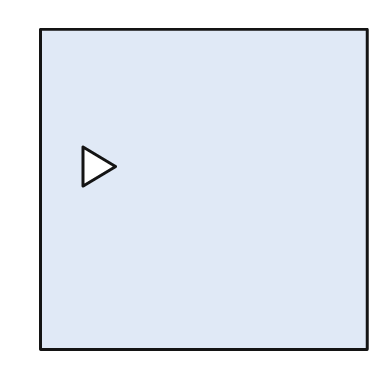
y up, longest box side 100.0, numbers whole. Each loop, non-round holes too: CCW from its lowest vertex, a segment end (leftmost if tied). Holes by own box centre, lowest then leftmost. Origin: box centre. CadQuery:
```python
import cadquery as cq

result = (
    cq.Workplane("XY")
    .moveTo(-50.0, -49.0)
    .lineTo(50.0, -49.0)
    .lineTo(50.0, 49.0)
    .lineTo(-50.0, 49.0)
    .close()
    .moveTo(-37.0, 1.0)
    .lineTo(-27.0, 7.0)
    .lineTo(-37.0, 13.0)
    .close()
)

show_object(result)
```